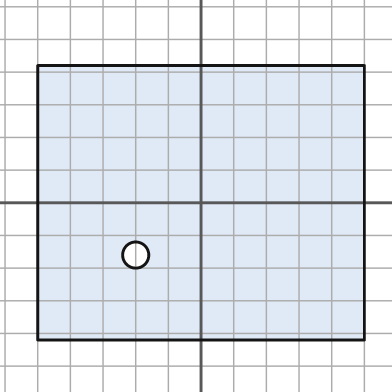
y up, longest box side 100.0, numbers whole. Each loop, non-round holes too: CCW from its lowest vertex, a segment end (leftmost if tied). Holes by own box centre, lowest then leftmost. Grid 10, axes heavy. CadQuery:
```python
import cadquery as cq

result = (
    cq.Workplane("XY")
    .moveTo(-50.0, -42.0)
    .lineTo(50.0, -42.0)
    .lineTo(50.0, 42.0)
    .lineTo(-50.0, 42.0)
    .close()
    .moveTo(-20.0, -16.0)
    .circle(4.0)
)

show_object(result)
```